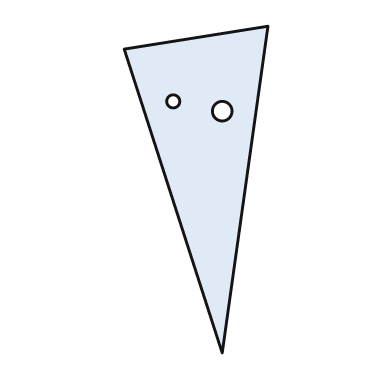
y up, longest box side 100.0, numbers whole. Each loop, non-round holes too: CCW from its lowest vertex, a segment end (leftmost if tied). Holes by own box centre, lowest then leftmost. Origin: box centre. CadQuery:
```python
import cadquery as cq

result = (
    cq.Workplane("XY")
    .moveTo(8.0, -50.0)
    .lineTo(22.0, 50.0)
    .lineTo(-22.0, 43.0)
    .close()
    .moveTo(8.0, 24.0)
    .circle(3.0)
    .moveTo(-7.0, 27.0)
    .circle(2.0)
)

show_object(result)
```